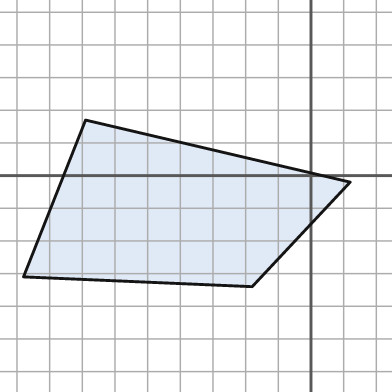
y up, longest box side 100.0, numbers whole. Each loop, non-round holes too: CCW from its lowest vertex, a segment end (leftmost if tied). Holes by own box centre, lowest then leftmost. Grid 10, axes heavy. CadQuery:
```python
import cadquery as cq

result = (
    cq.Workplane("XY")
    .moveTo(-18.0, -34.0)
    .lineTo(12.0, -2.0)
    .lineTo(-69.0, 17.0)
    .lineTo(-88.0, -31.0)
    .close()
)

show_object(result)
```